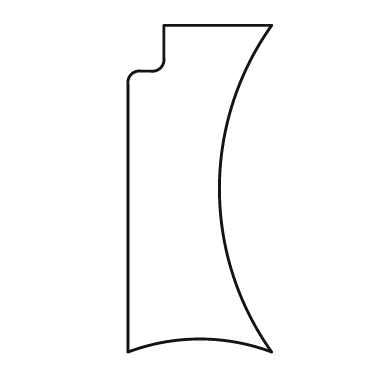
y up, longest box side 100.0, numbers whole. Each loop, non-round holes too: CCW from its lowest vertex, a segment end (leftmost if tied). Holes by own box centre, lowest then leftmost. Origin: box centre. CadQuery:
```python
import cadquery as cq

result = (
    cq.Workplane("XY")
    .moveTo(-22.0, -50.0)
    .threePointArc((0.0, -46.0), (22.0, -50.0))
    .threePointArc((6.0, 0.0), (22.0, 50.0))
    .lineTo(-11.0, 50.0)
    .lineTo(-11.0, 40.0)
    .threePointArc((-12.0, 37.0), (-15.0, 36.0))
    .lineTo(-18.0, 36.0)
    .threePointArc((-21.0, 35.0), (-22.0, 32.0))
    .close()
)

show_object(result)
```